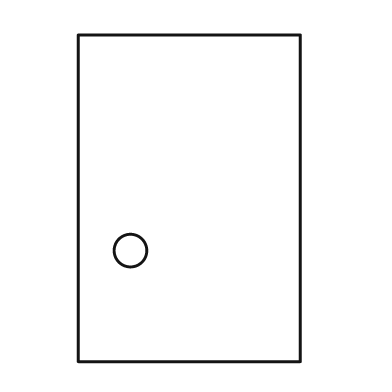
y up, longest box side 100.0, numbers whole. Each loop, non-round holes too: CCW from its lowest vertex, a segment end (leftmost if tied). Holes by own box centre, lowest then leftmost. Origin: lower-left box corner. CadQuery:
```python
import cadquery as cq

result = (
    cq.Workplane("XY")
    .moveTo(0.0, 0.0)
    .lineTo(68.0, 0.0)
    .lineTo(68.0, 100.0)
    .lineTo(0.0, 100.0)
    .close()
    .moveTo(16.0, 34.0)
    .circle(5.0)
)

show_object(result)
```